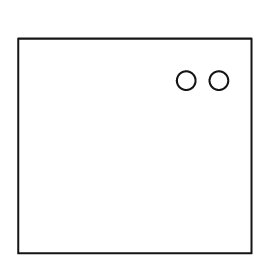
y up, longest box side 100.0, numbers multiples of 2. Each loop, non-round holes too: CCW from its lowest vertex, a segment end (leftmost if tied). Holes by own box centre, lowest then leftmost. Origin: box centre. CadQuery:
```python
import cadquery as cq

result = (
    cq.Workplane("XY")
    .moveTo(-50.0, -46.0)
    .lineTo(50.0, -46.0)
    .lineTo(50.0, 46.0)
    .lineTo(-50.0, 46.0)
    .close()
    .moveTo(22.0, 28.0)
    .circle(4.0)
    .moveTo(36.0, 28.0)
    .circle(4.0)
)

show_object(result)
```